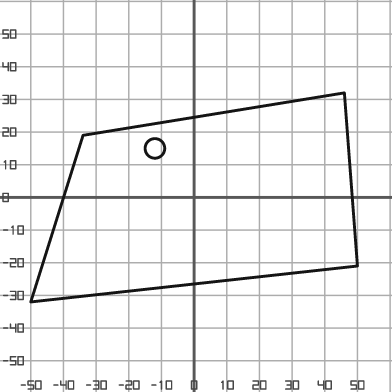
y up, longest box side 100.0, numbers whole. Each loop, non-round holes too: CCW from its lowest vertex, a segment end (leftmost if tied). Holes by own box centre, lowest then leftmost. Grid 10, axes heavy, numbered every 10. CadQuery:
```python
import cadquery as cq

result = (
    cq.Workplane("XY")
    .moveTo(-50.0, -32.0)
    .lineTo(50.0, -21.0)
    .lineTo(46.0, 32.0)
    .lineTo(-34.0, 19.0)
    .close()
    .moveTo(-12.0, 15.0)
    .circle(3.0)
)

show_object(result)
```